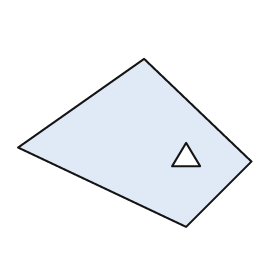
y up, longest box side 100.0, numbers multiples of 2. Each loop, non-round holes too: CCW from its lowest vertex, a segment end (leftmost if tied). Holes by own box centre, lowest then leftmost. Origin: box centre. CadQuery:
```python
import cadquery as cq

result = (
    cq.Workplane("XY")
    .moveTo(22.0, -36.0)
    .lineTo(50.0, -8.0)
    .lineTo(4.0, 36.0)
    .lineTo(-50.0, -2.0)
    .close()
    .moveTo(16.0, -10.0)
    .lineTo(28.0, -10.0)
    .lineTo(22.0, 0.0)
    .close()
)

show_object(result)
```